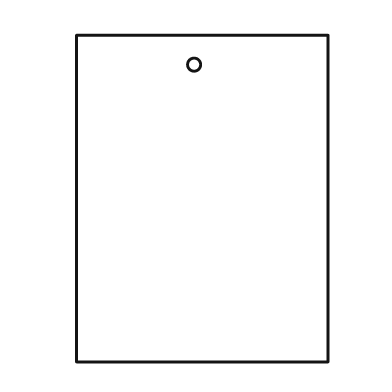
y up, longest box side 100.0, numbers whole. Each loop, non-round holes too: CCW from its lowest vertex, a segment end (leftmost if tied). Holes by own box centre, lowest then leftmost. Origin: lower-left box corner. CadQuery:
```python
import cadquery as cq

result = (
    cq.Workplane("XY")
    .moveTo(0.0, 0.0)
    .lineTo(77.0, 0.0)
    .lineTo(77.0, 100.0)
    .lineTo(0.0, 100.0)
    .close()
    .moveTo(36.0, 91.0)
    .circle(2.0)
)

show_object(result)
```